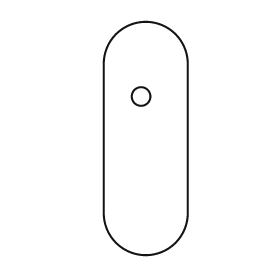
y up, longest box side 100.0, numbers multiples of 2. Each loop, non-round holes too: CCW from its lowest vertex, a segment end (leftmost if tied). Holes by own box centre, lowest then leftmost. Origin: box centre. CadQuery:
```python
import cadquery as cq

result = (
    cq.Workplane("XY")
    .moveTo(-18.0, -32.0)
    .threePointArc((0.0, -50.0), (18.0, -32.0))
    .lineTo(18.0, 32.0)
    .threePointArc((0.0, 50.0), (-18.0, 32.0))
    .close()
    .moveTo(-2.0, 18.0)
    .circle(4.0)
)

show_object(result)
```